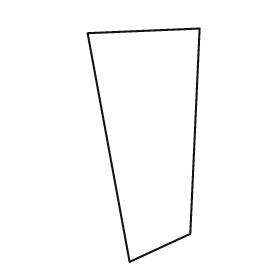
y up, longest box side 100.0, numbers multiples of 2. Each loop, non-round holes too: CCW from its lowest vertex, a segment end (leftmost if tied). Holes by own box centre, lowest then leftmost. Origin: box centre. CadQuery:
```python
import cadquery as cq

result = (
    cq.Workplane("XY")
    .moveTo(-6.0, -50.0)
    .lineTo(20.0, -38.0)
    .lineTo(24.0, 50.0)
    .lineTo(-24.0, 48.0)
    .close()
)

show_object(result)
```